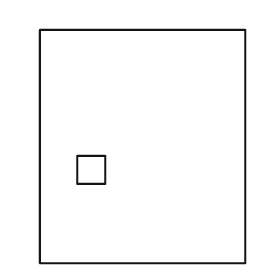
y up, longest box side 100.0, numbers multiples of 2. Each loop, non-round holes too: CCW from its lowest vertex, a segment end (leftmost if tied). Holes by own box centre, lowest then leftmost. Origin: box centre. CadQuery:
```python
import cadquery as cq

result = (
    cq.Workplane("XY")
    .moveTo(-44.0, -50.0)
    .lineTo(44.0, -50.0)
    .lineTo(44.0, 50.0)
    .lineTo(-44.0, 50.0)
    .close()
    .moveTo(-28.0, -16.0)
    .lineTo(-16.0, -16.0)
    .lineTo(-16.0, -4.0)
    .lineTo(-28.0, -4.0)
    .close()
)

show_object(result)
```